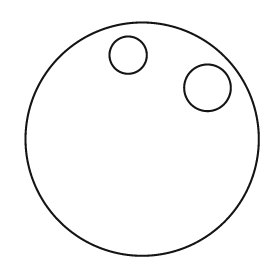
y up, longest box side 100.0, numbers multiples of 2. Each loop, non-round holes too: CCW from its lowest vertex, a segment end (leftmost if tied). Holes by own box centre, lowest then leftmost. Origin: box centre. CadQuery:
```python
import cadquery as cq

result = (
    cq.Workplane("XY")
    .moveTo(0.0, 0.0)
    .circle(50.0)
    .moveTo(28.0, 22.0)
    .circle(10.0)
    .moveTo(-6.0, 36.0)
    .circle(8.0)
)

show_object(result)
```